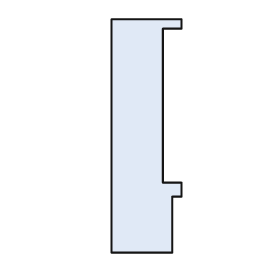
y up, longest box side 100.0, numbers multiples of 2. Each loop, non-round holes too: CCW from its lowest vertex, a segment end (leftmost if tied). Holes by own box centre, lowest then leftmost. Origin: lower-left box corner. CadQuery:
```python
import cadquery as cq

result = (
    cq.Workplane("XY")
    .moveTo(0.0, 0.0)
    .lineTo(26.0, 0.0)
    .lineTo(26.0, 24.0)
    .lineTo(30.0, 24.0)
    .lineTo(30.0, 30.0)
    .lineTo(22.0, 30.0)
    .lineTo(22.0, 96.0)
    .lineTo(30.0, 96.0)
    .lineTo(30.0, 100.0)
    .lineTo(0.0, 100.0)
    .close()
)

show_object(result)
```